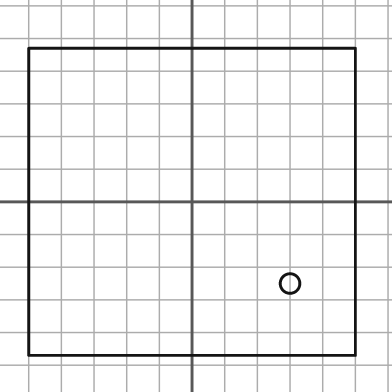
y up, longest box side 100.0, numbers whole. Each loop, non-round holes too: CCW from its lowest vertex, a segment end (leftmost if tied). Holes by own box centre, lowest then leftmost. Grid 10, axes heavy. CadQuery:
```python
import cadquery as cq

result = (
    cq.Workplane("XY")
    .moveTo(-50.0, -47.0)
    .lineTo(50.0, -47.0)
    .lineTo(50.0, 47.0)
    .lineTo(-50.0, 47.0)
    .close()
    .moveTo(30.0, -25.0)
    .circle(3.0)
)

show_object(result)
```